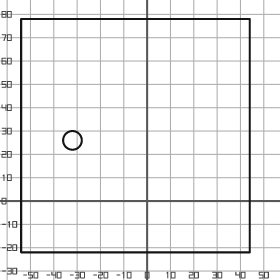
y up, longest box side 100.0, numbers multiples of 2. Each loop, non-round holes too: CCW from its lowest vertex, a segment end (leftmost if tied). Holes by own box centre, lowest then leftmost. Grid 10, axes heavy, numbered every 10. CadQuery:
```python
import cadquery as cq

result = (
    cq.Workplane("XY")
    .moveTo(-54.0, -22.0)
    .lineTo(44.0, -22.0)
    .lineTo(44.0, 78.0)
    .lineTo(-54.0, 78.0)
    .close()
    .moveTo(-32.0, 26.0)
    .circle(4.0)
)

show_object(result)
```